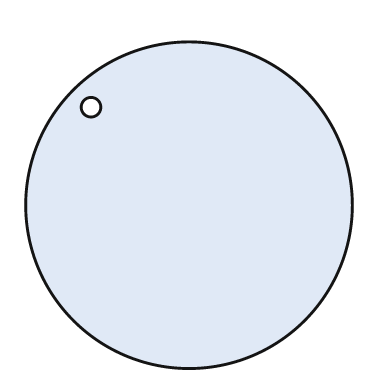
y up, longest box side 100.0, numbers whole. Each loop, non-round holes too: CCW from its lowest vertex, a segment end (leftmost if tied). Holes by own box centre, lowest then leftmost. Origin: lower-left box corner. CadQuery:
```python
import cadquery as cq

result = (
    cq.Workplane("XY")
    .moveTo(50.0, 50.0)
    .circle(50.0)
    .moveTo(20.0, 80.0)
    .circle(3.0)
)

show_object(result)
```